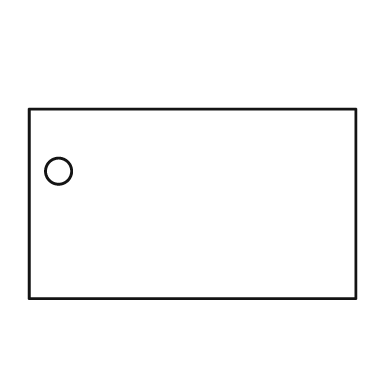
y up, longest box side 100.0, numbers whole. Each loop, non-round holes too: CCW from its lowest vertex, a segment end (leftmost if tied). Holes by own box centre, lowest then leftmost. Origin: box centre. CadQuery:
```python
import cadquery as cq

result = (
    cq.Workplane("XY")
    .moveTo(-50.0, -29.0)
    .lineTo(50.0, -29.0)
    .lineTo(50.0, 29.0)
    .lineTo(-50.0, 29.0)
    .close()
    .moveTo(-41.0, 10.0)
    .circle(4.0)
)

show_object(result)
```